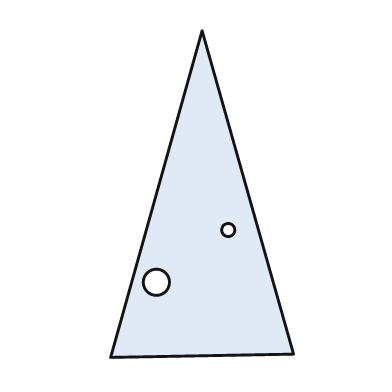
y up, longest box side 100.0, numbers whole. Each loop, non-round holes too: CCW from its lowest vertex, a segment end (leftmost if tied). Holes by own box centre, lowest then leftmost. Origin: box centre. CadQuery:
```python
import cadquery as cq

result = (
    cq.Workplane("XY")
    .moveTo(-28.0, -50.0)
    .lineTo(28.0, -49.0)
    .lineTo(0.0, 50.0)
    .close()
    .moveTo(-14.0, -27.0)
    .circle(4.0)
    .moveTo(8.0, -11.0)
    .circle(2.0)
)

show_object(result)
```